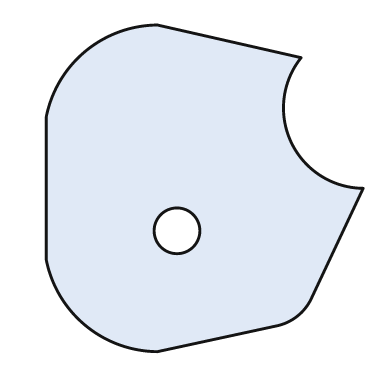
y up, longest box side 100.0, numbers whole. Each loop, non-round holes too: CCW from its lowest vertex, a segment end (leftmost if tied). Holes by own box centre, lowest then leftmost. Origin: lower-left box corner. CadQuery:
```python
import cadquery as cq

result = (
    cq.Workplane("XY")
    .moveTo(34.0, 0.0)
    .lineTo(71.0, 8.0)
    .threePointArc((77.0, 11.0), (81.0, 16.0))
    .lineTo(97.0, 50.0)
    .threePointArc((75.0, 64.0), (78.0, 90.0))
    .lineTo(34.0, 100.0)
    .threePointArc((12.0, 92.0), (0.0, 72.0))
    .lineTo(0.0, 28.0)
    .threePointArc((12.0, 8.0), (34.0, 0.0))
    .close()
    .moveTo(40.0, 37.0)
    .circle(7.0)
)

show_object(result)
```